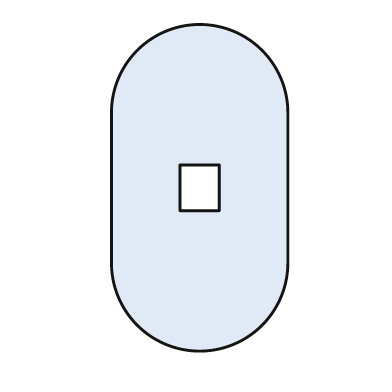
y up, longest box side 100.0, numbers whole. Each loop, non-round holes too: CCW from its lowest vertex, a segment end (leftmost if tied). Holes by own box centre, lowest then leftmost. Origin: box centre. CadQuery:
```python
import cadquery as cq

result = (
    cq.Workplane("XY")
    .moveTo(-27.0, -23.0)
    .threePointArc((0.0, -50.0), (27.0, -23.0))
    .lineTo(27.0, 23.0)
    .threePointArc((0.0, 50.0), (-27.0, 23.0))
    .close()
    .moveTo(-6.0, -7.0)
    .lineTo(6.0, -7.0)
    .lineTo(6.0, 7.0)
    .lineTo(-6.0, 7.0)
    .close()
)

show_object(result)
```